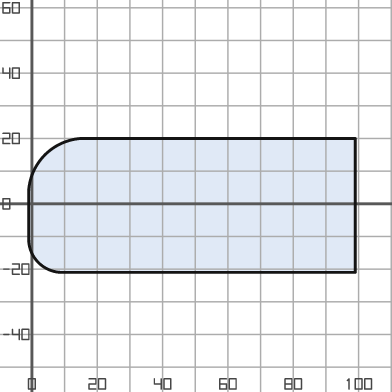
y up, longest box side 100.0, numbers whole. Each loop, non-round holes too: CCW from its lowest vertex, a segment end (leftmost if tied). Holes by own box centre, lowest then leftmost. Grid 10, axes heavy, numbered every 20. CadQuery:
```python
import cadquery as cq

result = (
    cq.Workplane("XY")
    .moveTo(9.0, -21.0)
    .lineTo(99.0, -21.0)
    .lineTo(99.0, 20.0)
    .lineTo(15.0, 20.0)
    .threePointArc((4.0, 15.0), (-1.0, 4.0))
    .lineTo(-1.0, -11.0)
    .threePointArc((2.0, -18.0), (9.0, -21.0))
    .close()
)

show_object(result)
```